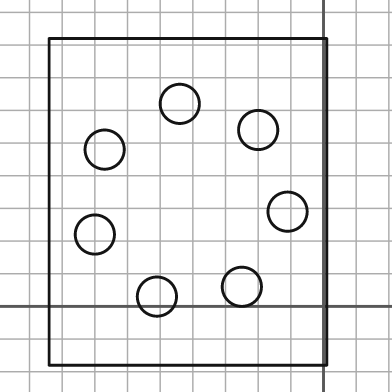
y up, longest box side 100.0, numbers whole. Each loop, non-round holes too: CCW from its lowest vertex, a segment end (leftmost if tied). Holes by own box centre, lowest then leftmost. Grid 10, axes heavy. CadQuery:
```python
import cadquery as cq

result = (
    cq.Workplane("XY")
    .moveTo(-84.0, -18.0)
    .lineTo(1.0, -18.0)
    .lineTo(1.0, 82.0)
    .lineTo(-84.0, 82.0)
    .close()
    .moveTo(-51.0, 3.0)
    .circle(6.0)
    .moveTo(-25.0, 6.0)
    .circle(6.0)
    .moveTo(-70.0, 22.0)
    .circle(6.0)
    .moveTo(-11.0, 29.0)
    .circle(6.0)
    .moveTo(-67.0, 48.0)
    .circle(6.0)
    .moveTo(-20.0, 54.0)
    .circle(6.0)
    .moveTo(-44.0, 62.0)
    .circle(6.0)
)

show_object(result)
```